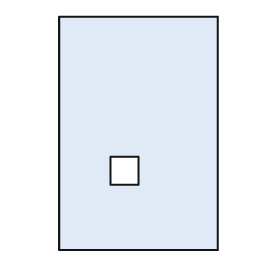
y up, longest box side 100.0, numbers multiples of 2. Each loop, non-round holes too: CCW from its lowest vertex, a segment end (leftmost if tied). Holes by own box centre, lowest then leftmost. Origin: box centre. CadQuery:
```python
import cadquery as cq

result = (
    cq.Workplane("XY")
    .moveTo(-34.0, -50.0)
    .lineTo(34.0, -50.0)
    .lineTo(34.0, 50.0)
    .lineTo(-34.0, 50.0)
    .close()
    .moveTo(-12.0, -22.0)
    .lineTo(0.0, -22.0)
    .lineTo(0.0, -10.0)
    .lineTo(-12.0, -10.0)
    .close()
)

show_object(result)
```